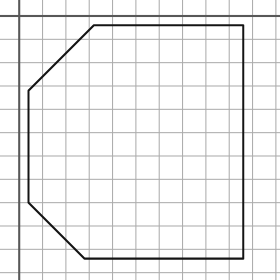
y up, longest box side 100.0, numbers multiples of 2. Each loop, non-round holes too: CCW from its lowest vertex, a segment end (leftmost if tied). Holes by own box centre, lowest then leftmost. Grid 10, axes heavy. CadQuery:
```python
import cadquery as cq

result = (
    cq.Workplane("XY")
    .moveTo(28.0, -104.0)
    .lineTo(96.0, -104.0)
    .lineTo(96.0, -4.0)
    .lineTo(32.0, -4.0)
    .lineTo(4.0, -32.0)
    .lineTo(4.0, -80.0)
    .close()
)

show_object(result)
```